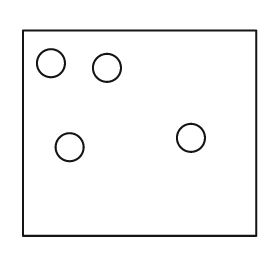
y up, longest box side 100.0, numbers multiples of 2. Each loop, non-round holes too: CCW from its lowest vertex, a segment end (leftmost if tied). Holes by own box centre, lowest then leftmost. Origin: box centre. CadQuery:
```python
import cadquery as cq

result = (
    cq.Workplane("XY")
    .moveTo(-50.0, -44.0)
    .lineTo(50.0, -44.0)
    .lineTo(50.0, 44.0)
    .lineTo(-50.0, 44.0)
    .close()
    .moveTo(-30.0, -6.0)
    .circle(6.0)
    .moveTo(22.0, -2.0)
    .circle(6.0)
    .moveTo(-14.0, 28.0)
    .circle(6.0)
    .moveTo(-38.0, 30.0)
    .circle(6.0)
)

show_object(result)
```